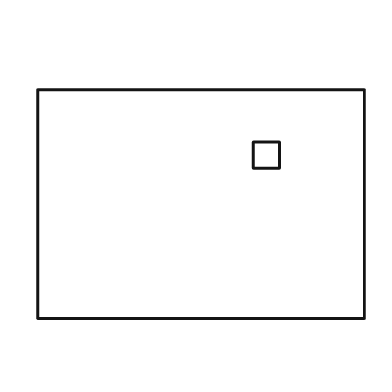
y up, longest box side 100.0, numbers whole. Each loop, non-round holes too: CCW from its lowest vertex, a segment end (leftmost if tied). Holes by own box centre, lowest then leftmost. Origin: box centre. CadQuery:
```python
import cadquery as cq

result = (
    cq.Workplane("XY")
    .moveTo(-50.0, -35.0)
    .lineTo(50.0, -35.0)
    .lineTo(50.0, 35.0)
    .lineTo(-50.0, 35.0)
    .close()
    .moveTo(16.0, 11.0)
    .lineTo(24.0, 11.0)
    .lineTo(24.0, 19.0)
    .lineTo(16.0, 19.0)
    .close()
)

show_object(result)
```